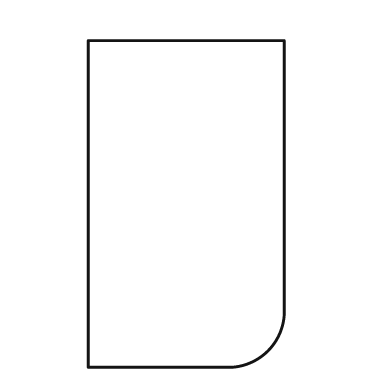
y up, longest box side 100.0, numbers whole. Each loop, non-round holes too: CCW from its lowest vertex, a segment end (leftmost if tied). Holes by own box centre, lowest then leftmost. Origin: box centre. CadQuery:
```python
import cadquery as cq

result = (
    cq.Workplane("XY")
    .moveTo(-30.0, -50.0)
    .lineTo(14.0, -50.0)
    .threePointArc((25.0, -45.0), (30.0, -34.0))
    .lineTo(30.0, 50.0)
    .lineTo(-30.0, 50.0)
    .close()
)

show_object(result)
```